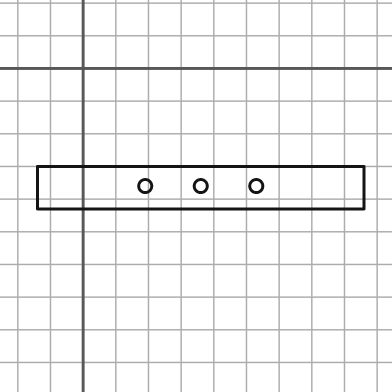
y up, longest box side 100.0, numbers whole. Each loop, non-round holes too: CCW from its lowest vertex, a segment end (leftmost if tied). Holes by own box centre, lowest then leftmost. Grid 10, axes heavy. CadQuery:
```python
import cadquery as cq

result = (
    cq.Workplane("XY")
    .moveTo(-14.0, -43.0)
    .lineTo(86.0, -43.0)
    .lineTo(86.0, -30.0)
    .lineTo(-14.0, -30.0)
    .close()
    .moveTo(19.0, -36.0)
    .circle(2.0)
    .moveTo(36.0, -36.0)
    .circle(2.0)
    .moveTo(53.0, -36.0)
    .circle(2.0)
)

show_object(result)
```